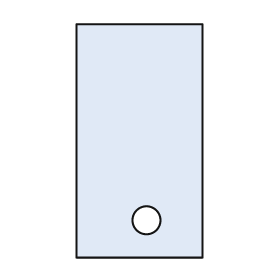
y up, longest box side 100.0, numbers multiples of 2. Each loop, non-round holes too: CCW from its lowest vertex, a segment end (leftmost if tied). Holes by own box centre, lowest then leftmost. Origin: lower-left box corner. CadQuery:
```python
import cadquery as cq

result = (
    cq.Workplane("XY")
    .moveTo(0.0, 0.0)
    .lineTo(54.0, 0.0)
    .lineTo(54.0, 100.0)
    .lineTo(0.0, 100.0)
    .close()
    .moveTo(30.0, 16.0)
    .circle(6.0)
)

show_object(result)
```